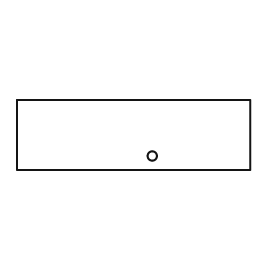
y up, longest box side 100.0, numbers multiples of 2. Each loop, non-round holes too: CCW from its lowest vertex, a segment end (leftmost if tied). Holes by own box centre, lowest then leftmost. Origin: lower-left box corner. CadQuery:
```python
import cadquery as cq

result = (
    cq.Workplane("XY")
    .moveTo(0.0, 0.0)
    .lineTo(100.0, 0.0)
    .lineTo(100.0, 30.0)
    .lineTo(0.0, 30.0)
    .close()
    .moveTo(58.0, 6.0)
    .circle(2.0)
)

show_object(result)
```